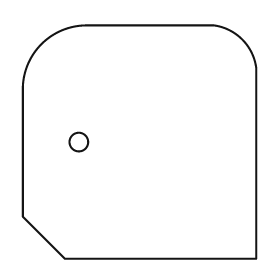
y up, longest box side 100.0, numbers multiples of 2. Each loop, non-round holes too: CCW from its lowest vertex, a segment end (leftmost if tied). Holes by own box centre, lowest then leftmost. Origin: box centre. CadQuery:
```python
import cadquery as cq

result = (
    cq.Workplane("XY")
    .moveTo(-32.0, -50.0)
    .lineTo(50.0, -50.0)
    .lineTo(50.0, 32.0)
    .threePointArc((44.0, 44.0), (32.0, 50.0))
    .lineTo(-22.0, 50.0)
    .threePointArc((-42.0, 42.0), (-50.0, 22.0))
    .lineTo(-50.0, -32.0)
    .close()
    .moveTo(-26.0, 0.0)
    .circle(4.0)
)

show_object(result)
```